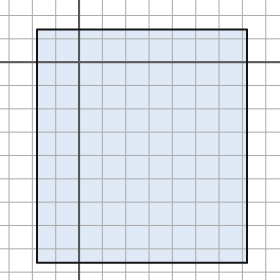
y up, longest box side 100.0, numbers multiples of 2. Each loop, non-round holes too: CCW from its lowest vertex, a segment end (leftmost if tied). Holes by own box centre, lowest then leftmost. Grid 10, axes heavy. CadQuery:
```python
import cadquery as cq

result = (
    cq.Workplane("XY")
    .moveTo(-18.0, -86.0)
    .lineTo(72.0, -86.0)
    .lineTo(72.0, 14.0)
    .lineTo(-18.0, 14.0)
    .close()
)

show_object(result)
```